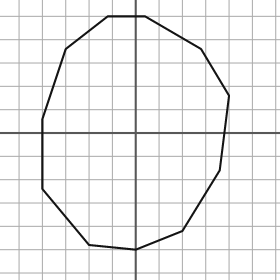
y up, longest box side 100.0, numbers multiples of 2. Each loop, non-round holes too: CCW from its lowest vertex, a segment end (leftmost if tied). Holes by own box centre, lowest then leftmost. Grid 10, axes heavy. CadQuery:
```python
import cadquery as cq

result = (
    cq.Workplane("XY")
    .moveTo(0.0, -50.0)
    .lineTo(20.0, -42.0)
    .lineTo(36.0, -16.0)
    .lineTo(40.0, 16.0)
    .lineTo(28.0, 36.0)
    .lineTo(4.0, 50.0)
    .lineTo(-12.0, 50.0)
    .lineTo(-30.0, 36.0)
    .lineTo(-40.0, 6.0)
    .lineTo(-40.0, -24.0)
    .lineTo(-20.0, -48.0)
    .close()
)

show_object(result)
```